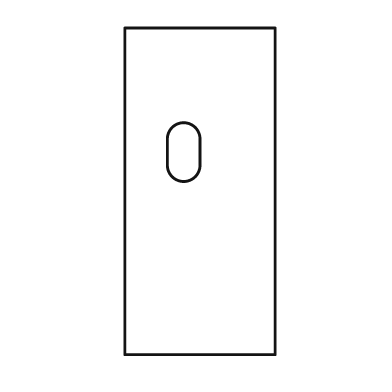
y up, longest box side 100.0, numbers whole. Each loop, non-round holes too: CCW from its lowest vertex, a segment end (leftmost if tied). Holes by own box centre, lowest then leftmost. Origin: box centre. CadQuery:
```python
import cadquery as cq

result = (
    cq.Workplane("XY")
    .moveTo(-23.0, -50.0)
    .lineTo(23.0, -50.0)
    .lineTo(23.0, 50.0)
    .lineTo(-23.0, 50.0)
    .close()
    .moveTo(-10.0, 8.0)
    .threePointArc((-5.0, 3.0), (0.0, 8.0))
    .lineTo(0.0, 16.0)
    .threePointArc((-5.0, 21.0), (-10.0, 16.0))
    .close()
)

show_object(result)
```